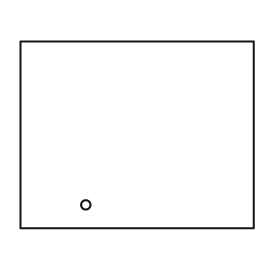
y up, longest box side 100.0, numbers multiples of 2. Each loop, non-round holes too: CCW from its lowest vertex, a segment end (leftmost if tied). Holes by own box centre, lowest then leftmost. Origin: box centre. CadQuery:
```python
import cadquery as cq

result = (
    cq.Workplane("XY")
    .moveTo(-50.0, -40.0)
    .lineTo(50.0, -40.0)
    .lineTo(50.0, 40.0)
    .lineTo(-50.0, 40.0)
    .close()
    .moveTo(-22.0, -30.0)
    .circle(2.0)
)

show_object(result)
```